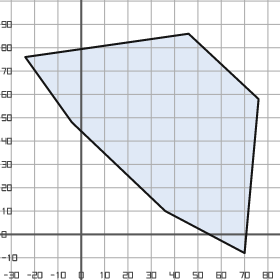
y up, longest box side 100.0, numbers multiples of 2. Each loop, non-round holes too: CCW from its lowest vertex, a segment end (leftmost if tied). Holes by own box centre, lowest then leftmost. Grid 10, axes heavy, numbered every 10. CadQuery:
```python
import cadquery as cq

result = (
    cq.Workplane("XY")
    .moveTo(70.0, -8.0)
    .lineTo(76.0, 58.0)
    .lineTo(46.0, 86.0)
    .lineTo(-24.0, 76.0)
    .lineTo(-4.0, 48.0)
    .lineTo(36.0, 10.0)
    .close()
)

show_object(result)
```